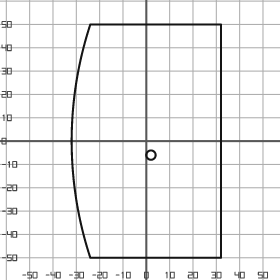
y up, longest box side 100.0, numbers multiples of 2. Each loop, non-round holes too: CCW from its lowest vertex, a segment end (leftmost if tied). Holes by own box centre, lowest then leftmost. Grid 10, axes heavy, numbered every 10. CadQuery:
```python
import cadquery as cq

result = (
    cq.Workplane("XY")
    .moveTo(-24.0, -50.0)
    .lineTo(32.0, -50.0)
    .lineTo(32.0, 50.0)
    .lineTo(-24.0, 50.0)
    .threePointArc((-32.0, 0.0), (-24.0, -50.0))
    .close()
    .moveTo(2.0, -6.0)
    .circle(2.0)
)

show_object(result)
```